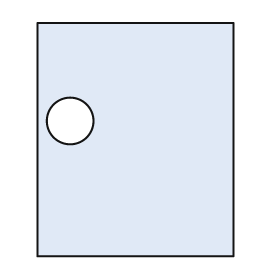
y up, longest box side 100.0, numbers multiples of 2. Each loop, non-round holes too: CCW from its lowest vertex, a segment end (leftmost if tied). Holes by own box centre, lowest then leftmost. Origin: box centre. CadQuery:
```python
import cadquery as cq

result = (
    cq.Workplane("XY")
    .moveTo(-42.0, -50.0)
    .lineTo(42.0, -50.0)
    .lineTo(42.0, 50.0)
    .lineTo(-42.0, 50.0)
    .close()
    .moveTo(-28.0, 8.0)
    .circle(10.0)
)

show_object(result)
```